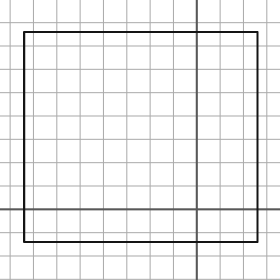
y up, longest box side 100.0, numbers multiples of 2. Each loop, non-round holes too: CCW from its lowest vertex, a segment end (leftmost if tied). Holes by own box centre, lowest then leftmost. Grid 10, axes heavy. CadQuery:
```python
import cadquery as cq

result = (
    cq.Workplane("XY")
    .moveTo(-74.0, -14.0)
    .lineTo(26.0, -14.0)
    .lineTo(26.0, 76.0)
    .lineTo(-74.0, 76.0)
    .close()
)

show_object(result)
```